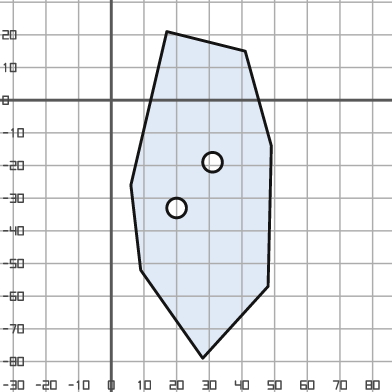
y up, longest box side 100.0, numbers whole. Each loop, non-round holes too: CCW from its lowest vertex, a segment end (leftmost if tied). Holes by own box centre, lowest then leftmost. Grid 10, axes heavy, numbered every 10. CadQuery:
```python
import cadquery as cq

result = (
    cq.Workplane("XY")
    .moveTo(28.0, -79.0)
    .lineTo(48.0, -57.0)
    .lineTo(49.0, -14.0)
    .lineTo(41.0, 15.0)
    .lineTo(17.0, 21.0)
    .lineTo(6.0, -26.0)
    .lineTo(9.0, -52.0)
    .close()
    .moveTo(20.0, -33.0)
    .circle(3.0)
    .moveTo(31.0, -19.0)
    .circle(3.0)
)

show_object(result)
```